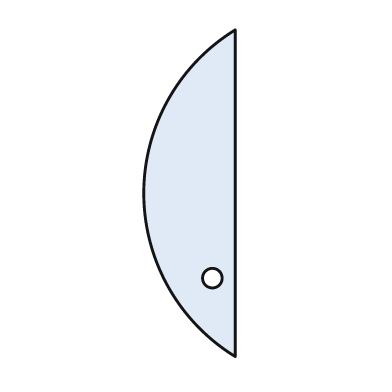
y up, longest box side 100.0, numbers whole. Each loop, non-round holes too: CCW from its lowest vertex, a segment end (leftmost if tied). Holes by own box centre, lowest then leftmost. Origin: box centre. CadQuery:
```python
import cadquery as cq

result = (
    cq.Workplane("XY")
    .moveTo(14.0, -50.0)
    .lineTo(14.0, 50.0)
    .threePointArc((-14.0, 0.0), (14.0, -50.0))
    .close()
    .moveTo(7.0, -26.0)
    .circle(3.0)
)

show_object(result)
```